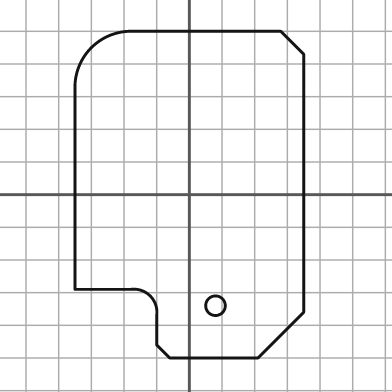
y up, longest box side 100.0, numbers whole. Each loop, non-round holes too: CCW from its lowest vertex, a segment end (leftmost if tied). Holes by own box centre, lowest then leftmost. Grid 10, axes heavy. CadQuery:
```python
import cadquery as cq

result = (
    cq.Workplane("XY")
    .moveTo(-6.0, -50.0)
    .lineTo(21.0, -50.0)
    .lineTo(35.0, -36.0)
    .lineTo(35.0, 43.0)
    .lineTo(28.0, 50.0)
    .lineTo(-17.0, 50.0)
    .threePointArc((-30.0, 45.0), (-35.0, 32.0))
    .lineTo(-35.0, -29.0)
    .lineTo(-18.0, -29.0)
    .threePointArc((-12.0, -31.0), (-10.0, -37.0))
    .lineTo(-10.0, -46.0)
    .close()
    .moveTo(8.0, -34.0)
    .circle(3.0)
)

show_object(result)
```